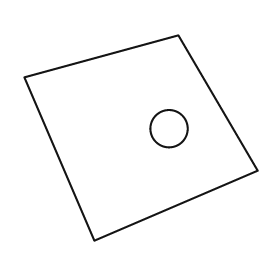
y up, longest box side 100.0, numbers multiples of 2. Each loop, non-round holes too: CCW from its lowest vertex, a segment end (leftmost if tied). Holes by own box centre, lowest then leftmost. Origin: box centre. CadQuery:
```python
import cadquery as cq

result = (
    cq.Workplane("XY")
    .moveTo(-20.0, -44.0)
    .lineTo(50.0, -14.0)
    .lineTo(16.0, 44.0)
    .lineTo(-50.0, 26.0)
    .close()
    .moveTo(12.0, 4.0)
    .circle(8.0)
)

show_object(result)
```